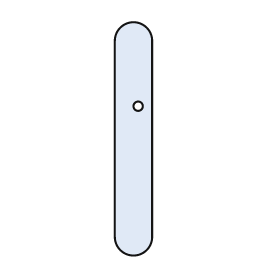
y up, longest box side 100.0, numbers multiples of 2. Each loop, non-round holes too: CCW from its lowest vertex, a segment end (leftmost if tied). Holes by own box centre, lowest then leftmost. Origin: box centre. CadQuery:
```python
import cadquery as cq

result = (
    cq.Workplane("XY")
    .moveTo(-8.0, -42.0)
    .threePointArc((0.0, -50.0), (8.0, -42.0))
    .lineTo(8.0, 42.0)
    .threePointArc((0.0, 50.0), (-8.0, 42.0))
    .close()
    .moveTo(2.0, 14.0)
    .circle(2.0)
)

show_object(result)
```